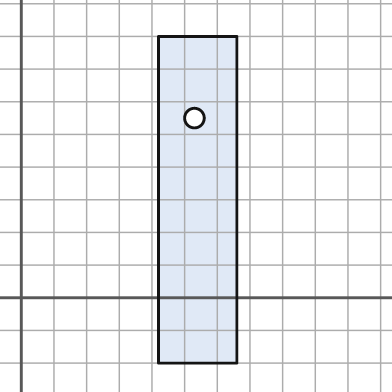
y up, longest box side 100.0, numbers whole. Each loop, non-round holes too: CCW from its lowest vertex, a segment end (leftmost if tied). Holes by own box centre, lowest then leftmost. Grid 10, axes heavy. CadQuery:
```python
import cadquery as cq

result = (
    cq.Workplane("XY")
    .moveTo(42.0, -20.0)
    .lineTo(66.0, -20.0)
    .lineTo(66.0, 80.0)
    .lineTo(42.0, 80.0)
    .close()
    .moveTo(53.0, 55.0)
    .circle(3.0)
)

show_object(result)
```